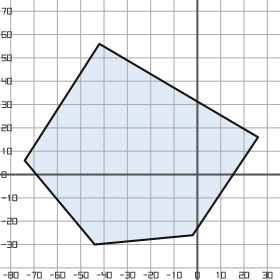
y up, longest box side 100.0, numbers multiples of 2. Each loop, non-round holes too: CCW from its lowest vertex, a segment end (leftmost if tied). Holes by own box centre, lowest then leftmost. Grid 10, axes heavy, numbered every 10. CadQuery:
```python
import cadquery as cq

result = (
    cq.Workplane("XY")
    .moveTo(-44.0, -30.0)
    .lineTo(-2.0, -26.0)
    .lineTo(26.0, 16.0)
    .lineTo(-42.0, 56.0)
    .lineTo(-74.0, 6.0)
    .close()
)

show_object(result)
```